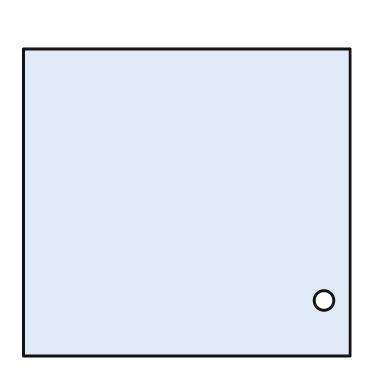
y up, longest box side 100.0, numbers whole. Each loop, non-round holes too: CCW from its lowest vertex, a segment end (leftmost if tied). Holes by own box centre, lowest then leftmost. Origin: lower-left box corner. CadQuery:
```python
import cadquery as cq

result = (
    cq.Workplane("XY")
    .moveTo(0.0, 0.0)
    .lineTo(100.0, 0.0)
    .lineTo(100.0, 94.0)
    .lineTo(0.0, 94.0)
    .close()
    .moveTo(92.0, 17.0)
    .circle(3.0)
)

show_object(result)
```